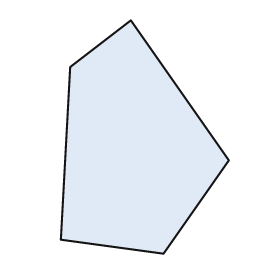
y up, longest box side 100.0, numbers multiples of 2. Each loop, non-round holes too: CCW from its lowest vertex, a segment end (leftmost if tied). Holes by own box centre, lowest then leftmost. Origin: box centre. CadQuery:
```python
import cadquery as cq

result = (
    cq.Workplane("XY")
    .moveTo(8.0, -50.0)
    .lineTo(36.0, -10.0)
    .lineTo(-6.0, 50.0)
    .lineTo(-32.0, 30.0)
    .lineTo(-36.0, -44.0)
    .close()
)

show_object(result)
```